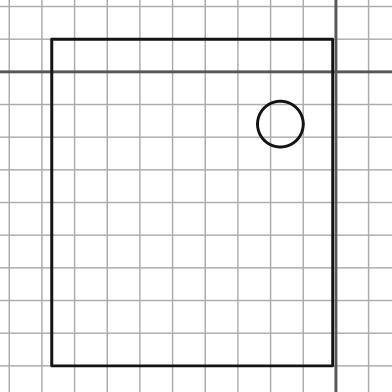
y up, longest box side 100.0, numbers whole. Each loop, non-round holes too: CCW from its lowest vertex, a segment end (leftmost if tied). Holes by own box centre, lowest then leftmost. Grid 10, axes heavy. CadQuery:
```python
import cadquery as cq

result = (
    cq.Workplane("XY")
    .moveTo(-87.0, -90.0)
    .lineTo(-1.0, -90.0)
    .lineTo(-1.0, 10.0)
    .lineTo(-87.0, 10.0)
    .close()
    .moveTo(-17.0, -16.0)
    .circle(7.0)
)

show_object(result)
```